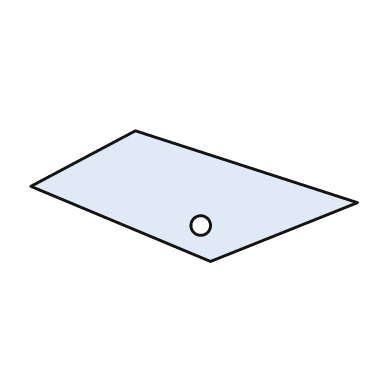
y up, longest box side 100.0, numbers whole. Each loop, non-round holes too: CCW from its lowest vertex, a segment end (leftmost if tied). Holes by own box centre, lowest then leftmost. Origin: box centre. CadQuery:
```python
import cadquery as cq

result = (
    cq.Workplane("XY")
    .moveTo(5.0, -20.0)
    .lineTo(50.0, -2.0)
    .lineTo(-18.0, 20.0)
    .lineTo(-50.0, 3.0)
    .close()
    .moveTo(2.0, -9.0)
    .circle(3.0)
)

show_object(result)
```